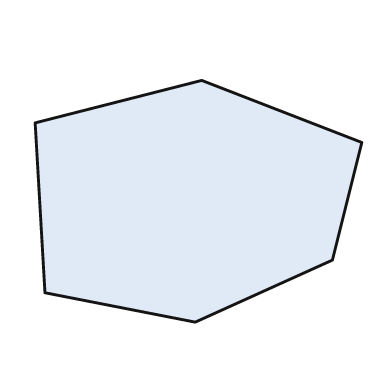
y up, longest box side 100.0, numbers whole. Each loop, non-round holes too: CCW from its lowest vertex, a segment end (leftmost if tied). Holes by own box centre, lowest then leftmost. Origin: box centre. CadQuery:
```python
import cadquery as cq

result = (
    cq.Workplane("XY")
    .moveTo(-1.0, -37.0)
    .lineTo(41.0, -18.0)
    .lineTo(50.0, 18.0)
    .lineTo(1.0, 37.0)
    .lineTo(-50.0, 24.0)
    .lineTo(-47.0, -28.0)
    .close()
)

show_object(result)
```